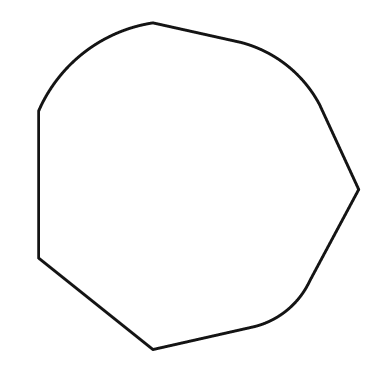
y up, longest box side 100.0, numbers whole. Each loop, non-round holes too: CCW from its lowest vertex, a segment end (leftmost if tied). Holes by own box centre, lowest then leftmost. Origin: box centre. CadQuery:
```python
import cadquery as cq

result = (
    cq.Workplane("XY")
    .moveTo(-14.0, -50.0)
    .lineTo(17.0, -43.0)
    .threePointArc((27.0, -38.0), (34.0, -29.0))
    .lineTo(49.0, -1.0)
    .lineTo(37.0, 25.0)
    .threePointArc((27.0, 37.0), (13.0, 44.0))
    .lineTo(-14.0, 50.0)
    .threePointArc((-35.0, 41.0), (-49.0, 23.0))
    .lineTo(-49.0, -22.0)
    .close()
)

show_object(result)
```